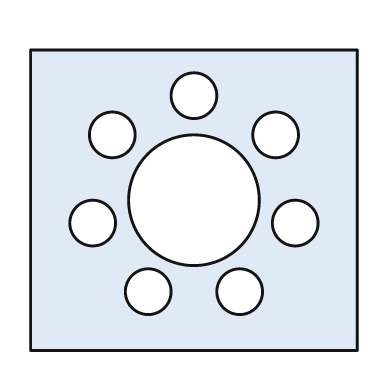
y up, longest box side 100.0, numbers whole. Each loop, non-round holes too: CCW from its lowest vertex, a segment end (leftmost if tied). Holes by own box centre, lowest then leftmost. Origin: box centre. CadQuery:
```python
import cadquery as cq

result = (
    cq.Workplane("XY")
    .moveTo(-50.0, -46.0)
    .lineTo(50.0, -46.0)
    .lineTo(50.0, 46.0)
    .lineTo(-50.0, 46.0)
    .close()
    .moveTo(-14.0, -28.0)
    .circle(7.0)
    .moveTo(14.0, -28.0)
    .circle(7.0)
    .moveTo(-31.0, -7.0)
    .circle(7.0)
    .moveTo(31.0, -7.0)
    .circle(7.0)
    .moveTo(0.0, 0.0)
    .circle(20.0)
    .moveTo(-25.0, 20.0)
    .circle(7.0)
    .moveTo(25.0, 20.0)
    .circle(7.0)
    .moveTo(0.0, 32.0)
    .circle(7.0)
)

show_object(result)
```